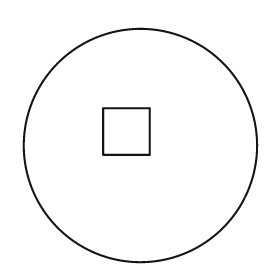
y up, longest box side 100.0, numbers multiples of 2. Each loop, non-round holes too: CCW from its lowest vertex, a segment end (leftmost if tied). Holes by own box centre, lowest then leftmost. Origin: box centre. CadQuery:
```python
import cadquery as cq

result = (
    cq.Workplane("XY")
    .moveTo(0.0, 0.0)
    .circle(50.0)
    .moveTo(-16.0, -4.0)
    .lineTo(4.0, -4.0)
    .lineTo(4.0, 16.0)
    .lineTo(-16.0, 16.0)
    .close()
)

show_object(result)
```